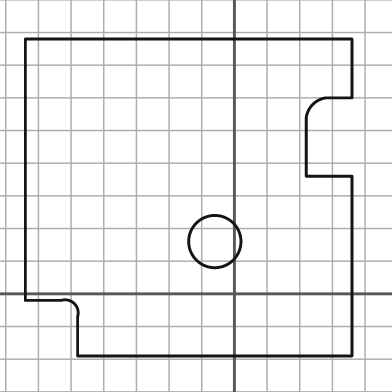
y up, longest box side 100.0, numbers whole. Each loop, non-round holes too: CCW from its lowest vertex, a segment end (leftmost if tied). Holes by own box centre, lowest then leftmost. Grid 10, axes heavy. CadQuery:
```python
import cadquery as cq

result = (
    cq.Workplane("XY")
    .moveTo(-48.0, -19.0)
    .lineTo(36.0, -19.0)
    .lineTo(36.0, 36.0)
    .lineTo(22.0, 36.0)
    .lineTo(22.0, 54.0)
    .threePointArc((24.0, 58.0), (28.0, 60.0))
    .lineTo(36.0, 60.0)
    .lineTo(36.0, 78.0)
    .lineTo(-64.0, 78.0)
    .lineTo(-64.0, -2.0)
    .lineTo(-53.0, -2.0)
    .threePointArc((-49.0, -3.0), (-48.0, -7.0))
    .close()
    .moveTo(-6.0, 16.0)
    .circle(8.0)
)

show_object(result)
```